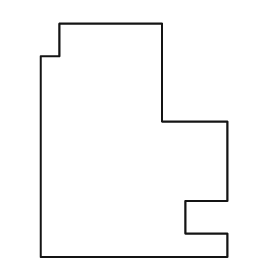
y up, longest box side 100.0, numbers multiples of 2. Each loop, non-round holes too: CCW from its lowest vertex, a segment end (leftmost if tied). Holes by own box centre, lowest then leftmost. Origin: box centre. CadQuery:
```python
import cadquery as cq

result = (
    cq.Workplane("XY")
    .moveTo(-40.0, -50.0)
    .lineTo(40.0, -50.0)
    .lineTo(40.0, -40.0)
    .lineTo(22.0, -40.0)
    .lineTo(22.0, -26.0)
    .lineTo(40.0, -26.0)
    .lineTo(40.0, 8.0)
    .lineTo(12.0, 8.0)
    .lineTo(12.0, 50.0)
    .lineTo(-32.0, 50.0)
    .lineTo(-32.0, 36.0)
    .lineTo(-40.0, 36.0)
    .close()
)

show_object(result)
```